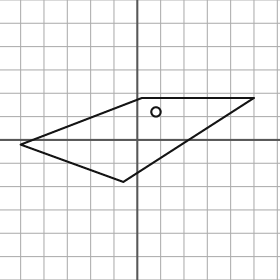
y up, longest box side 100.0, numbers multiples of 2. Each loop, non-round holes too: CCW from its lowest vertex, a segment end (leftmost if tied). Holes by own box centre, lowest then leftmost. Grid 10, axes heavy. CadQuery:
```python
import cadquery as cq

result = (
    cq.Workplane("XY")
    .moveTo(-6.0, -18.0)
    .lineTo(50.0, 18.0)
    .lineTo(2.0, 18.0)
    .lineTo(-50.0, -2.0)
    .close()
    .moveTo(8.0, 12.0)
    .circle(2.0)
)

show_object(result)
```